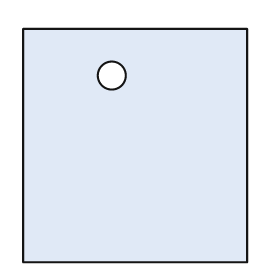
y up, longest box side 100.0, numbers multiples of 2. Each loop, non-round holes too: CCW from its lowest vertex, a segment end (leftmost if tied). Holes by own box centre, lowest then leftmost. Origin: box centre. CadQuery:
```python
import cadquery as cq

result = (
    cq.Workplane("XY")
    .moveTo(-48.0, -50.0)
    .lineTo(48.0, -50.0)
    .lineTo(48.0, 50.0)
    .lineTo(-48.0, 50.0)
    .close()
    .moveTo(-10.0, 30.0)
    .circle(6.0)
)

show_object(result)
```